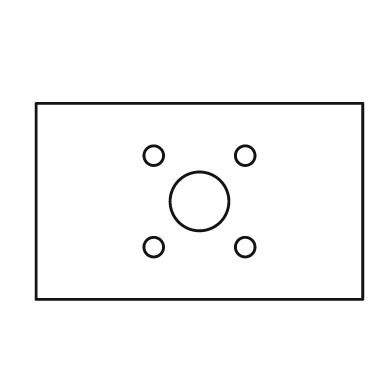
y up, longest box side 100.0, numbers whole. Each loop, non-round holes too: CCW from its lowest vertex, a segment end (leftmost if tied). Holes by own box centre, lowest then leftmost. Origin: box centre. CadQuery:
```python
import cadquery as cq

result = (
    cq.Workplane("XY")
    .moveTo(-50.0, -30.0)
    .lineTo(50.0, -30.0)
    .lineTo(50.0, 30.0)
    .lineTo(-50.0, 30.0)
    .close()
    .moveTo(-14.0, -14.0)
    .circle(3.0)
    .moveTo(14.0, -14.0)
    .circle(3.0)
    .moveTo(0.0, 0.0)
    .circle(9.0)
    .moveTo(-14.0, 14.0)
    .circle(3.0)
    .moveTo(14.0, 14.0)
    .circle(3.0)
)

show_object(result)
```